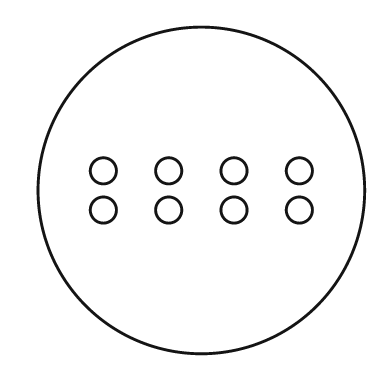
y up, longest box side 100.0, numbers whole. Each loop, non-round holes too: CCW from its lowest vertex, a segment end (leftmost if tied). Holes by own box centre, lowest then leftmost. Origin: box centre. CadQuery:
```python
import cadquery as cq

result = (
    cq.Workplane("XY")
    .moveTo(0.0, 0.0)
    .circle(50.0)
    .moveTo(-30.0, -6.0)
    .circle(4.0)
    .moveTo(-10.0, -6.0)
    .circle(4.0)
    .moveTo(10.0, -6.0)
    .circle(4.0)
    .moveTo(30.0, -6.0)
    .circle(4.0)
    .moveTo(-30.0, 6.0)
    .circle(4.0)
    .moveTo(-10.0, 6.0)
    .circle(4.0)
    .moveTo(10.0, 6.0)
    .circle(4.0)
    .moveTo(30.0, 6.0)
    .circle(4.0)
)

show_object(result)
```